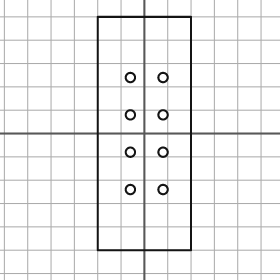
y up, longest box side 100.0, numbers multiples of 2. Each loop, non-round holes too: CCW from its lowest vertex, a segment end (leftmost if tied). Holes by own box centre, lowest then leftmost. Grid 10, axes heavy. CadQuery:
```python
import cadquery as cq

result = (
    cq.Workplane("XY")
    .moveTo(-20.0, -50.0)
    .lineTo(20.0, -50.0)
    .lineTo(20.0, 50.0)
    .lineTo(-20.0, 50.0)
    .close()
    .moveTo(-6.0, -24.0)
    .circle(2.0)
    .moveTo(8.0, -24.0)
    .circle(2.0)
    .moveTo(-6.0, -8.0)
    .circle(2.0)
    .moveTo(8.0, -8.0)
    .circle(2.0)
    .moveTo(-6.0, 8.0)
    .circle(2.0)
    .moveTo(8.0, 8.0)
    .circle(2.0)
    .moveTo(-6.0, 24.0)
    .circle(2.0)
    .moveTo(8.0, 24.0)
    .circle(2.0)
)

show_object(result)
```